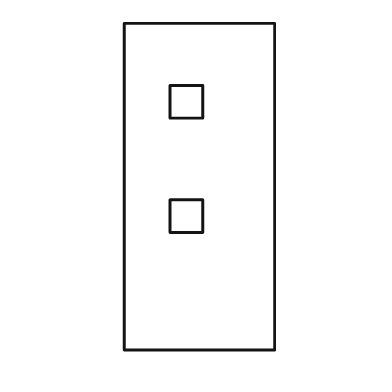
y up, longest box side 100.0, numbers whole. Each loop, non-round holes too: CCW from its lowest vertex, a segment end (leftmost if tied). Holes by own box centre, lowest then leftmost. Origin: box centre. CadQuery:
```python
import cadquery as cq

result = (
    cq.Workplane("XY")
    .moveTo(-23.0, -50.0)
    .lineTo(23.0, -50.0)
    .lineTo(23.0, 50.0)
    .lineTo(-23.0, 50.0)
    .close()
    .moveTo(-9.0, -14.0)
    .lineTo(1.0, -14.0)
    .lineTo(1.0, -4.0)
    .lineTo(-9.0, -4.0)
    .close()
    .moveTo(-9.0, 21.0)
    .lineTo(1.0, 21.0)
    .lineTo(1.0, 31.0)
    .lineTo(-9.0, 31.0)
    .close()
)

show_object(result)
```